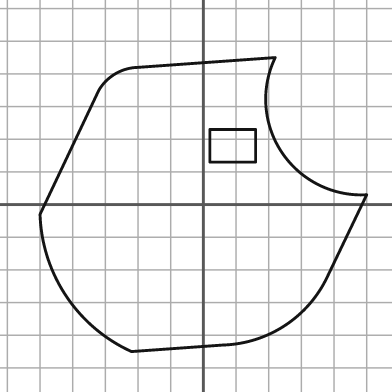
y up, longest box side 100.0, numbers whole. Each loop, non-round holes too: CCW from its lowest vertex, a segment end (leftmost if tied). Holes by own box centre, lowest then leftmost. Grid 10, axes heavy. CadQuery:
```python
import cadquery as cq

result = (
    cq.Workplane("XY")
    .moveTo(-22.0, -45.0)
    .lineTo(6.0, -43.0)
    .threePointArc((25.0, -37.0), (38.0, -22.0))
    .lineTo(50.0, 3.0)
    .threePointArc((24.0, 16.0), (22.0, 45.0))
    .lineTo(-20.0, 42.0)
    .threePointArc((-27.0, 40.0), (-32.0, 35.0))
    .lineTo(-50.0, -3.0)
    .threePointArc((-42.0, -28.0), (-22.0, -45.0))
    .close()
    .moveTo(2.0, 13.0)
    .lineTo(16.0, 13.0)
    .lineTo(16.0, 23.0)
    .lineTo(2.0, 23.0)
    .close()
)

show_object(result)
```